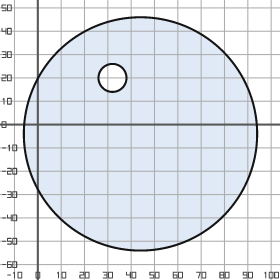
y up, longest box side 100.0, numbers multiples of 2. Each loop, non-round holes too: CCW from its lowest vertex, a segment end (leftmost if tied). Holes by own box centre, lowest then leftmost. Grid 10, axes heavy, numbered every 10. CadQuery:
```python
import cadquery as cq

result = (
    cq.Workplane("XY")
    .moveTo(44.0, -4.0)
    .circle(50.0)
    .moveTo(32.0, 20.0)
    .circle(6.0)
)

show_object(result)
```